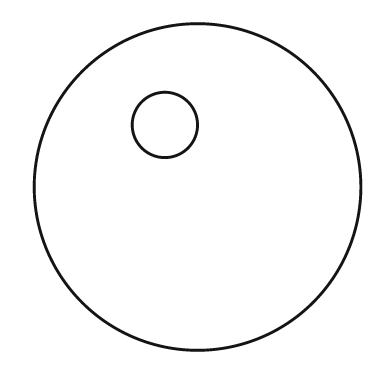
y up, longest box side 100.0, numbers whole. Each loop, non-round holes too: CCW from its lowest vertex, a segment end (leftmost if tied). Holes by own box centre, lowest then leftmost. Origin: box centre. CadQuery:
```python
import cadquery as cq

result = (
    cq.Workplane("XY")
    .moveTo(0.0, 0.0)
    .circle(50.0)
    .moveTo(-10.0, 19.0)
    .circle(10.0)
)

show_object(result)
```